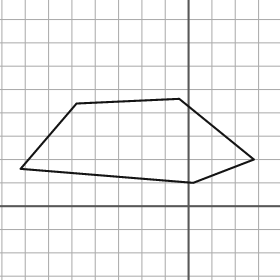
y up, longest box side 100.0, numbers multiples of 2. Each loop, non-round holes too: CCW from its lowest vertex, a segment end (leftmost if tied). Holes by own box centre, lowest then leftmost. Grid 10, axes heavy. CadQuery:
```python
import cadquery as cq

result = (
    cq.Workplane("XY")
    .moveTo(2.0, 10.0)
    .lineTo(28.0, 20.0)
    .lineTo(-4.0, 46.0)
    .lineTo(-48.0, 44.0)
    .lineTo(-72.0, 16.0)
    .close()
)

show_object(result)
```